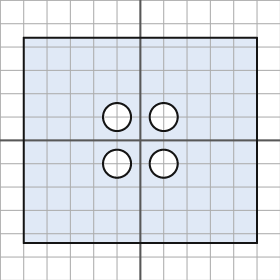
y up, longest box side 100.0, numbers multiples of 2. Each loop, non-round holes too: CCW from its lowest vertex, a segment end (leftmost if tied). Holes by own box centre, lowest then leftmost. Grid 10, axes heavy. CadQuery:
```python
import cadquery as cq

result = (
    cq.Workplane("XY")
    .moveTo(-50.0, -44.0)
    .lineTo(50.0, -44.0)
    .lineTo(50.0, 44.0)
    .lineTo(-50.0, 44.0)
    .close()
    .moveTo(-10.0, -10.0)
    .circle(6.0)
    .moveTo(10.0, -10.0)
    .circle(6.0)
    .moveTo(-10.0, 10.0)
    .circle(6.0)
    .moveTo(10.0, 10.0)
    .circle(6.0)
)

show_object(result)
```